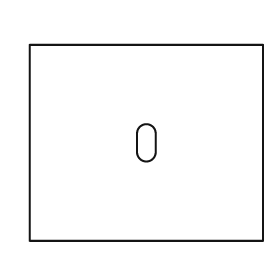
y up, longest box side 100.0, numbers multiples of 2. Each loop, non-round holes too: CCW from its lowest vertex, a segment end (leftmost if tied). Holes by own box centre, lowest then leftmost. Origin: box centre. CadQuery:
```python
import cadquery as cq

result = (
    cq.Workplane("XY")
    .moveTo(-50.0, -42.0)
    .lineTo(50.0, -42.0)
    .lineTo(50.0, 42.0)
    .lineTo(-50.0, 42.0)
    .close()
    .moveTo(-4.0, -4.0)
    .threePointArc((0.0, -8.0), (4.0, -4.0))
    .lineTo(4.0, 4.0)
    .threePointArc((0.0, 8.0), (-4.0, 4.0))
    .close()
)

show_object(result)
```